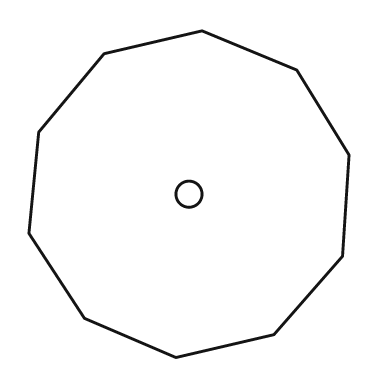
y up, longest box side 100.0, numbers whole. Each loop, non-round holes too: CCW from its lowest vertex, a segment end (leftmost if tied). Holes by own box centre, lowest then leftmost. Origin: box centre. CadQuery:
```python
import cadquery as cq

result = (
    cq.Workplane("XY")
    .moveTo(-4.0, -50.0)
    .lineTo(26.0, -43.0)
    .lineTo(47.0, -19.0)
    .lineTo(49.0, 12.0)
    .lineTo(33.0, 38.0)
    .lineTo(4.0, 50.0)
    .lineTo(-26.0, 43.0)
    .lineTo(-46.0, 19.0)
    .lineTo(-49.0, -12.0)
    .lineTo(-32.0, -38.0)
    .close()
    .moveTo(0.0, 0.0)
    .circle(4.0)
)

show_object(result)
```